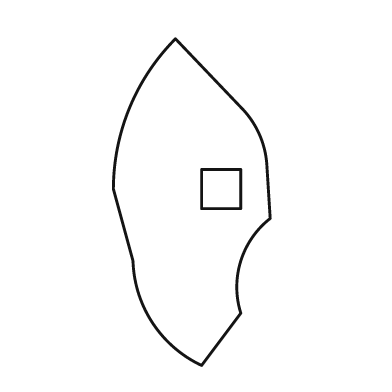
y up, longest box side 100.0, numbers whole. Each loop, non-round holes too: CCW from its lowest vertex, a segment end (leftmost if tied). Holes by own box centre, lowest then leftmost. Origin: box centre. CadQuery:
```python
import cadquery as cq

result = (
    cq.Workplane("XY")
    .moveTo(3.0, -50.0)
    .lineTo(15.0, -34.0)
    .threePointArc((15.0, -18.0), (24.0, -5.0))
    .lineTo(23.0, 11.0)
    .threePointArc((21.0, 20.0), (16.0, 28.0))
    .lineTo(-5.0, 50.0)
    .threePointArc((-19.0, 29.0), (-24.0, 4.0))
    .lineTo(-18.0, -18.0)
    .threePointArc((-12.0, -37.0), (3.0, -50.0))
    .close()
    .moveTo(3.0, -2.0)
    .lineTo(15.0, -2.0)
    .lineTo(15.0, 10.0)
    .lineTo(3.0, 10.0)
    .close()
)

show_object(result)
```